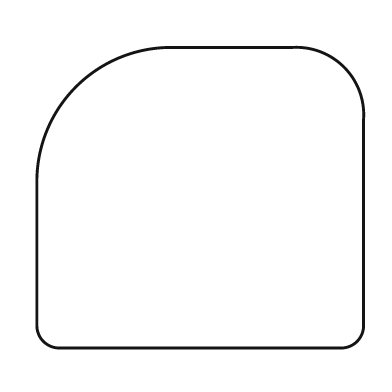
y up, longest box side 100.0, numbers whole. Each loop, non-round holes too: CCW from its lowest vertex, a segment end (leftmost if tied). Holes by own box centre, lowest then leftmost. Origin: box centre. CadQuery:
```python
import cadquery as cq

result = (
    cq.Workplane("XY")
    .moveTo(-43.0, -46.0)
    .lineTo(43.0, -46.0)
    .threePointArc((48.0, -44.0), (50.0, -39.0))
    .lineTo(50.0, 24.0)
    .threePointArc((44.0, 40.0), (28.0, 46.0))
    .lineTo(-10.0, 46.0)
    .threePointArc((-38.0, 34.0), (-50.0, 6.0))
    .lineTo(-50.0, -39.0)
    .threePointArc((-48.0, -44.0), (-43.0, -46.0))
    .close()
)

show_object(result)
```